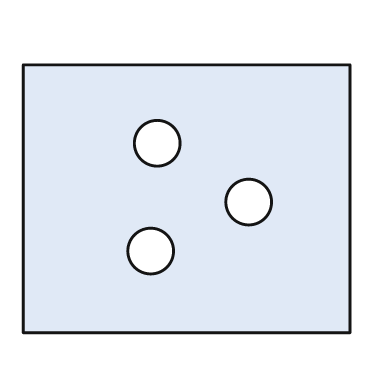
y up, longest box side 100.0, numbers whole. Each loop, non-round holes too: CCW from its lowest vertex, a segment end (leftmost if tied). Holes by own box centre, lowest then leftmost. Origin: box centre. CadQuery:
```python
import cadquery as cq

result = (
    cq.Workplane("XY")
    .moveTo(-50.0, -41.0)
    .lineTo(50.0, -41.0)
    .lineTo(50.0, 41.0)
    .lineTo(-50.0, 41.0)
    .close()
    .moveTo(-11.0, -16.0)
    .circle(7.0)
    .moveTo(19.0, -1.0)
    .circle(7.0)
    .moveTo(-9.0, 17.0)
    .circle(7.0)
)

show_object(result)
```